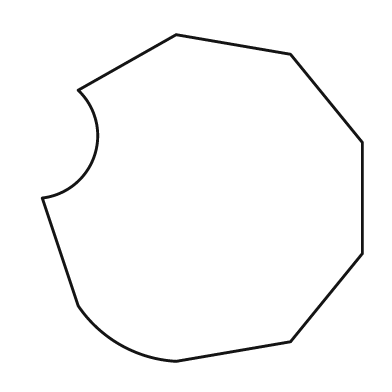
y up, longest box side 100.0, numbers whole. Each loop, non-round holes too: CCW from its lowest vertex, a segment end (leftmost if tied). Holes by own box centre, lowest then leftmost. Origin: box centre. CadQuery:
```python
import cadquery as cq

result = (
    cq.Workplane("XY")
    .moveTo(-8.0, -50.0)
    .lineTo(27.0, -44.0)
    .lineTo(49.0, -17.0)
    .lineTo(49.0, 17.0)
    .lineTo(27.0, 44.0)
    .lineTo(-8.0, 50.0)
    .lineTo(-38.0, 33.0)
    .threePointArc((-33.0, 13.0), (-49.0, 0.0))
    .lineTo(-38.0, -33.0)
    .threePointArc((-25.0, -45.0), (-8.0, -50.0))
    .close()
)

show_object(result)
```